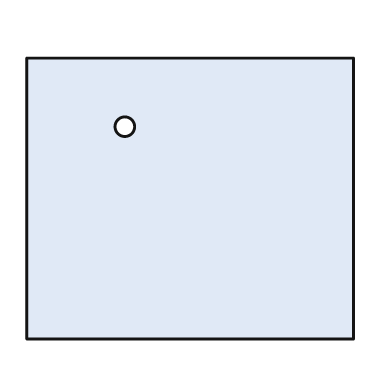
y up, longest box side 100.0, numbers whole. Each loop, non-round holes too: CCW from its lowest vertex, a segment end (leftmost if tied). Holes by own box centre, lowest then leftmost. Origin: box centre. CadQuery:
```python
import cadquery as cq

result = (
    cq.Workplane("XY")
    .moveTo(-50.0, -43.0)
    .lineTo(50.0, -43.0)
    .lineTo(50.0, 43.0)
    .lineTo(-50.0, 43.0)
    .close()
    .moveTo(-20.0, 22.0)
    .circle(3.0)
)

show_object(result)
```